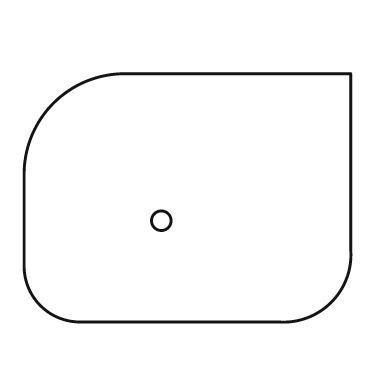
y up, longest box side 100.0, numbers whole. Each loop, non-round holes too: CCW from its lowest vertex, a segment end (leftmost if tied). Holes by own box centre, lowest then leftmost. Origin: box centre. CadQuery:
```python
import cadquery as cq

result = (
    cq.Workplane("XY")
    .moveTo(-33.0, -38.0)
    .lineTo(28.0, -38.0)
    .threePointArc((44.0, -32.0), (50.0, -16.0))
    .lineTo(50.0, 38.0)
    .lineTo(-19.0, 38.0)
    .threePointArc((-41.0, 29.0), (-50.0, 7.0))
    .lineTo(-50.0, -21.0)
    .threePointArc((-45.0, -33.0), (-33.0, -38.0))
    .close()
    .moveTo(-8.0, -7.0)
    .circle(3.0)
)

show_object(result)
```